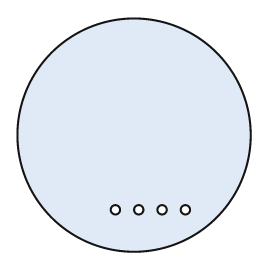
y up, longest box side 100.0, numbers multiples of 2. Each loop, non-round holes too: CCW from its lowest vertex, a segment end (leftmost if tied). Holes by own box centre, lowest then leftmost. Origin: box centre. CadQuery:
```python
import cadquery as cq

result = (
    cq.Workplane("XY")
    .moveTo(0.0, 0.0)
    .circle(50.0)
    .moveTo(-8.0, -32.0)
    .circle(2.0)
    .moveTo(2.0, -32.0)
    .circle(2.0)
    .moveTo(12.0, -32.0)
    .circle(2.0)
    .moveTo(22.0, -32.0)
    .circle(2.0)
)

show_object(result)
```